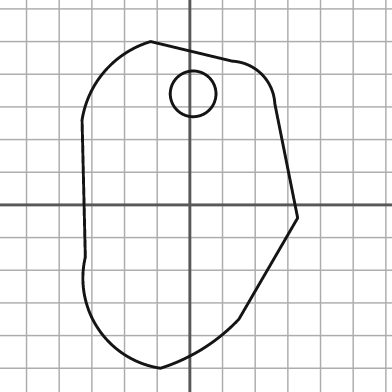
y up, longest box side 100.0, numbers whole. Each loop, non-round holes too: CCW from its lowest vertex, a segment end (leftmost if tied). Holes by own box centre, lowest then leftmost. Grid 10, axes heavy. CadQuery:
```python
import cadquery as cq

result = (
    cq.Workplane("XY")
    .moveTo(-9.0, -50.0)
    .threePointArc((4.0, -44.0), (15.0, -35.0))
    .lineTo(33.0, -4.0)
    .lineTo(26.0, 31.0)
    .threePointArc((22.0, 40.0), (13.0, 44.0))
    .lineTo(-12.0, 50.0)
    .threePointArc((-26.0, 41.0), (-33.0, 26.0))
    .lineTo(-32.0, -16.0)
    .threePointArc((-28.0, -38.0), (-9.0, -50.0))
    .close()
    .moveTo(1.0, 34.0)
    .circle(7.0)
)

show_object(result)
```